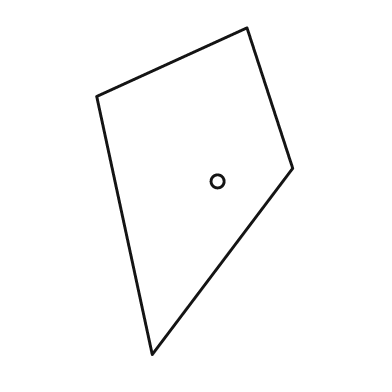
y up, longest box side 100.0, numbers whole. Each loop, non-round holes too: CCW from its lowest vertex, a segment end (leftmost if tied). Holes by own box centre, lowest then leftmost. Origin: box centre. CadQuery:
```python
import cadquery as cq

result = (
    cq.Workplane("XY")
    .moveTo(-13.0, -50.0)
    .lineTo(30.0, 7.0)
    .lineTo(16.0, 50.0)
    .lineTo(-30.0, 29.0)
    .close()
    .moveTo(7.0, 3.0)
    .circle(2.0)
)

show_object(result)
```